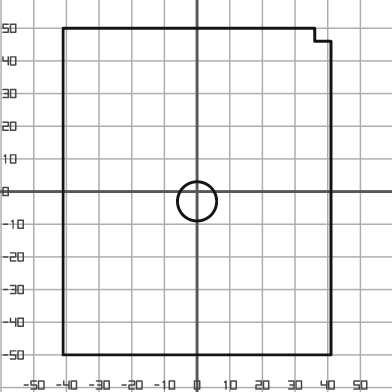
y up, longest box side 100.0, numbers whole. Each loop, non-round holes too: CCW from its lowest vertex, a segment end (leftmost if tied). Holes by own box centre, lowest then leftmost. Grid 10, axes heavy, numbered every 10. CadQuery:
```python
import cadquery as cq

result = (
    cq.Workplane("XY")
    .moveTo(-41.0, -50.0)
    .lineTo(41.0, -50.0)
    .lineTo(41.0, 46.0)
    .lineTo(36.0, 46.0)
    .lineTo(36.0, 50.0)
    .lineTo(-41.0, 50.0)
    .close()
    .moveTo(0.0, -3.0)
    .circle(6.0)
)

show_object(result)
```